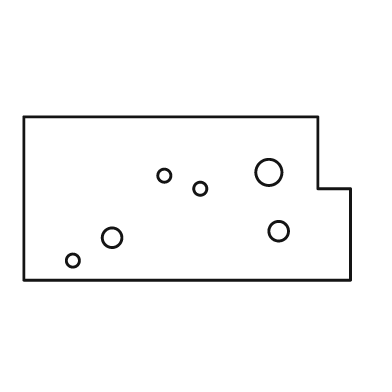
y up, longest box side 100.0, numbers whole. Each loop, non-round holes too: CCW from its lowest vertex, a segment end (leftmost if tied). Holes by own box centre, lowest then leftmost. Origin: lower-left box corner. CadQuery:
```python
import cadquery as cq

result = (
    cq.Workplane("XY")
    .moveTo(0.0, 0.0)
    .lineTo(100.0, 0.0)
    .lineTo(100.0, 28.0)
    .lineTo(90.0, 28.0)
    .lineTo(90.0, 50.0)
    .lineTo(0.0, 50.0)
    .close()
    .moveTo(15.0, 6.0)
    .circle(2.0)
    .moveTo(27.0, 13.0)
    .circle(3.0)
    .moveTo(78.0, 15.0)
    .circle(3.0)
    .moveTo(54.0, 28.0)
    .circle(2.0)
    .moveTo(43.0, 32.0)
    .circle(2.0)
    .moveTo(75.0, 33.0)
    .circle(4.0)
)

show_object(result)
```